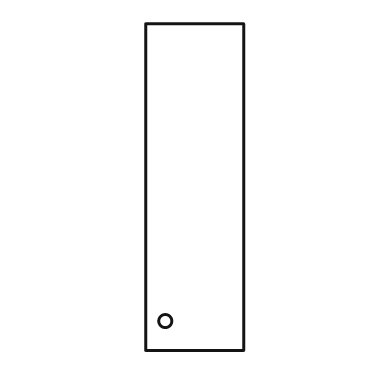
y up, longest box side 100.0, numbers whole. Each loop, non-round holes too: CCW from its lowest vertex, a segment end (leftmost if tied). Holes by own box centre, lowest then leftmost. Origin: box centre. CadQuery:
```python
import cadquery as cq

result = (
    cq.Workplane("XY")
    .moveTo(-15.0, -50.0)
    .lineTo(15.0, -50.0)
    .lineTo(15.0, 50.0)
    .lineTo(-15.0, 50.0)
    .close()
    .moveTo(-9.0, -41.0)
    .circle(2.0)
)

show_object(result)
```